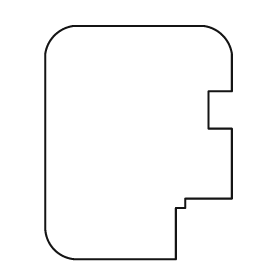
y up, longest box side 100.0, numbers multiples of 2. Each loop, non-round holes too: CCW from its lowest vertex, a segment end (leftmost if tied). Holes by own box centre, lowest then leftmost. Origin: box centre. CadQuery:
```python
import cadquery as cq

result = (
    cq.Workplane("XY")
    .moveTo(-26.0, -50.0)
    .lineTo(16.0, -50.0)
    .lineTo(16.0, -28.0)
    .lineTo(20.0, -28.0)
    .lineTo(20.0, -24.0)
    .lineTo(40.0, -24.0)
    .lineTo(40.0, 6.0)
    .lineTo(30.0, 6.0)
    .lineTo(30.0, 22.0)
    .lineTo(40.0, 22.0)
    .lineTo(40.0, 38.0)
    .threePointArc((36.0, 46.0), (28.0, 50.0))
    .lineTo(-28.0, 50.0)
    .threePointArc((-36.0, 46.0), (-40.0, 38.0))
    .lineTo(-40.0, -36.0)
    .threePointArc((-36.0, -46.0), (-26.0, -50.0))
    .close()
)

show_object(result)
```